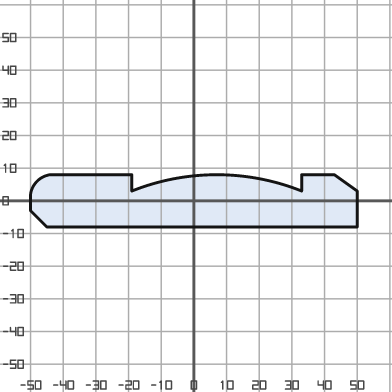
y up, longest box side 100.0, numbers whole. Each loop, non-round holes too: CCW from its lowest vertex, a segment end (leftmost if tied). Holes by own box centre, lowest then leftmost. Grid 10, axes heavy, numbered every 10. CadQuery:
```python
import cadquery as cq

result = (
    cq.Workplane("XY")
    .moveTo(-45.0, -8.0)
    .lineTo(50.0, -8.0)
    .lineTo(50.0, 3.0)
    .lineTo(43.0, 8.0)
    .lineTo(33.0, 8.0)
    .lineTo(33.0, 3.0)
    .threePointArc((7.0, 8.0), (-19.0, 3.0))
    .lineTo(-19.0, 8.0)
    .lineTo(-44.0, 8.0)
    .threePointArc((-48.0, 6.0), (-50.0, 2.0))
    .lineTo(-50.0, -3.0)
    .close()
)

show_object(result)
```